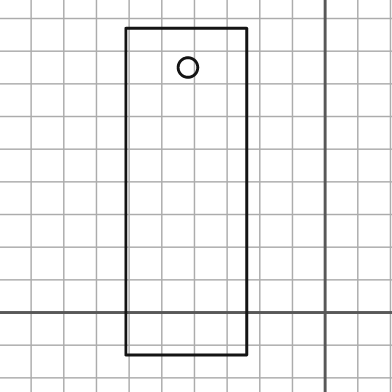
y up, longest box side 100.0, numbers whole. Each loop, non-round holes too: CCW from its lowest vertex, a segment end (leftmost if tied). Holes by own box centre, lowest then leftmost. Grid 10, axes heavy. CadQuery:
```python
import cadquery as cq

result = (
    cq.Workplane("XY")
    .moveTo(-61.0, -13.0)
    .lineTo(-24.0, -13.0)
    .lineTo(-24.0, 87.0)
    .lineTo(-61.0, 87.0)
    .close()
    .moveTo(-42.0, 75.0)
    .circle(3.0)
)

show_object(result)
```